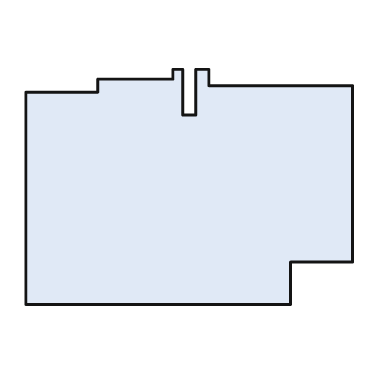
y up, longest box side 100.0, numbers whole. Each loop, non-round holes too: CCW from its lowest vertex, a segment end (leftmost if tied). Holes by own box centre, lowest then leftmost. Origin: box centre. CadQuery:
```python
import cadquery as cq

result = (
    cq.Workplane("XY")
    .moveTo(-50.0, -36.0)
    .lineTo(31.0, -36.0)
    .lineTo(31.0, -23.0)
    .lineTo(50.0, -23.0)
    .lineTo(50.0, 31.0)
    .lineTo(6.0, 31.0)
    .lineTo(6.0, 36.0)
    .lineTo(2.0, 36.0)
    .lineTo(2.0, 22.0)
    .lineTo(-2.0, 22.0)
    .lineTo(-2.0, 36.0)
    .lineTo(-5.0, 36.0)
    .lineTo(-5.0, 33.0)
    .lineTo(-28.0, 33.0)
    .lineTo(-28.0, 29.0)
    .lineTo(-50.0, 29.0)
    .close()
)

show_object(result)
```